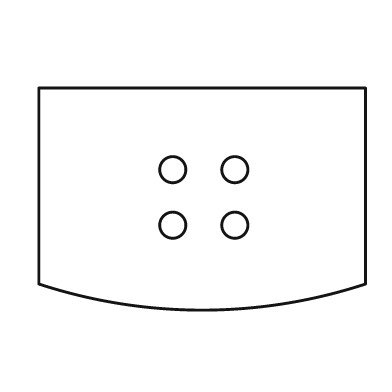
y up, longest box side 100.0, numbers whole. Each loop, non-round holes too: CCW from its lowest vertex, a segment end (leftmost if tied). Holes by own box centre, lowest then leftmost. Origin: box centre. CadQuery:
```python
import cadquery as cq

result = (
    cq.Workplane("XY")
    .moveTo(-50.0, -26.0)
    .threePointArc((0.0, -34.0), (50.0, -26.0))
    .lineTo(50.0, 34.0)
    .lineTo(-50.0, 34.0)
    .close()
    .moveTo(-9.0, -8.0)
    .circle(4.0)
    .moveTo(10.0, -8.0)
    .circle(4.0)
    .moveTo(-9.0, 9.0)
    .circle(4.0)
    .moveTo(10.0, 9.0)
    .circle(4.0)
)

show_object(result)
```